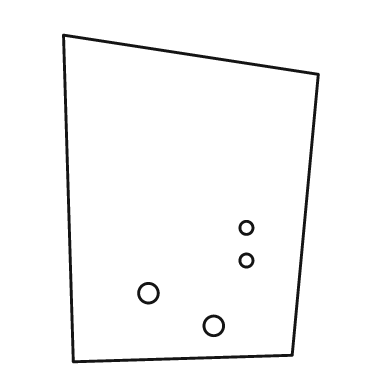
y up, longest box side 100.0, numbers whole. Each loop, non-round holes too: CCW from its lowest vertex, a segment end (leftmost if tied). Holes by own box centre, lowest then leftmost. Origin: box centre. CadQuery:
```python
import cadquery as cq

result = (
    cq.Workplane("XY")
    .moveTo(-36.0, -50.0)
    .lineTo(31.0, -48.0)
    .lineTo(39.0, 38.0)
    .lineTo(-39.0, 50.0)
    .close()
    .moveTo(7.0, -39.0)
    .circle(3.0)
    .moveTo(-13.0, -29.0)
    .circle(3.0)
    .moveTo(17.0, -19.0)
    .circle(2.0)
    .moveTo(17.0, -9.0)
    .circle(2.0)
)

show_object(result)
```